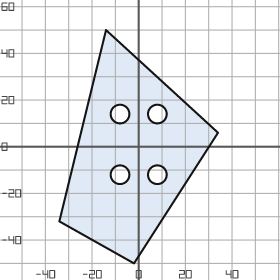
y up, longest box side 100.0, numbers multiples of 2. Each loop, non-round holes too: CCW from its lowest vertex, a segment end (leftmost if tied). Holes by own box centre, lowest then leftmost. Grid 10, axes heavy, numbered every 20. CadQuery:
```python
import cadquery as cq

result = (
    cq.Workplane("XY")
    .moveTo(-2.0, -50.0)
    .lineTo(34.0, 6.0)
    .lineTo(-14.0, 50.0)
    .lineTo(-34.0, -32.0)
    .close()
    .moveTo(-8.0, -12.0)
    .circle(4.0)
    .moveTo(8.0, -12.0)
    .circle(4.0)
    .moveTo(-8.0, 14.0)
    .circle(4.0)
    .moveTo(8.0, 14.0)
    .circle(4.0)
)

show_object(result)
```